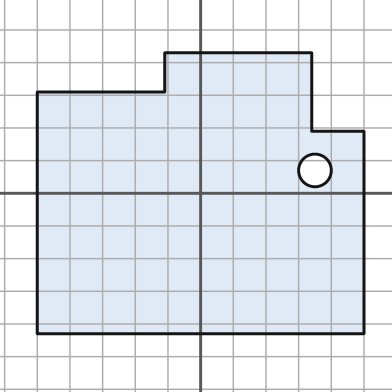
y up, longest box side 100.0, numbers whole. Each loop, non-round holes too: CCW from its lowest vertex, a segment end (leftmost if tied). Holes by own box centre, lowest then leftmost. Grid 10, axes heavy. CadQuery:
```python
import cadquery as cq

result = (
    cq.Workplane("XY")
    .moveTo(-50.0, -43.0)
    .lineTo(50.0, -43.0)
    .lineTo(50.0, 19.0)
    .lineTo(34.0, 19.0)
    .lineTo(34.0, 43.0)
    .lineTo(-11.0, 43.0)
    .lineTo(-11.0, 31.0)
    .lineTo(-50.0, 31.0)
    .close()
    .moveTo(35.0, 7.0)
    .circle(5.0)
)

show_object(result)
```